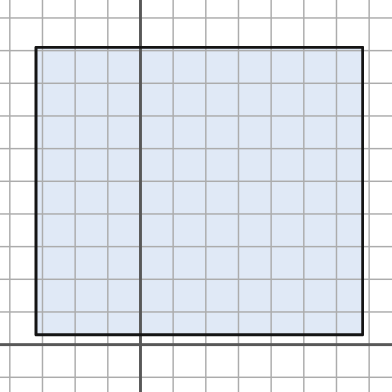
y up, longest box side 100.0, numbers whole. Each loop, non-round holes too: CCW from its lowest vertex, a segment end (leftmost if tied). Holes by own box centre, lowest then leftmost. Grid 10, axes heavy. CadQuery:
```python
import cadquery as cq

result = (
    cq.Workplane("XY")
    .moveTo(-32.0, 3.0)
    .lineTo(68.0, 3.0)
    .lineTo(68.0, 91.0)
    .lineTo(-32.0, 91.0)
    .close()
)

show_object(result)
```